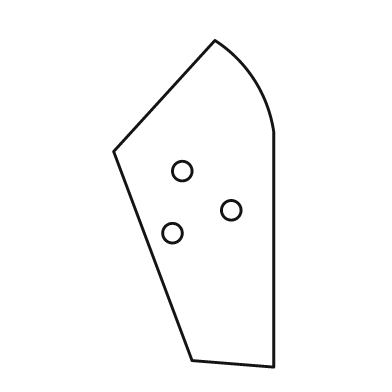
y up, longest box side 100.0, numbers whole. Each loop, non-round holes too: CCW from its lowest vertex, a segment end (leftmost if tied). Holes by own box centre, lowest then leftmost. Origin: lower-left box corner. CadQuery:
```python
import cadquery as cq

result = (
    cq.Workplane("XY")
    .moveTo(49.0, 0.0)
    .lineTo(49.0, 72.0)
    .threePointArc((43.0, 88.0), (31.0, 100.0))
    .lineTo(0.0, 66.0)
    .lineTo(24.0, 2.0)
    .close()
    .moveTo(18.0, 41.0)
    .circle(3.0)
    .moveTo(36.0, 48.0)
    .circle(3.0)
    .moveTo(21.0, 60.0)
    .circle(3.0)
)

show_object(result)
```